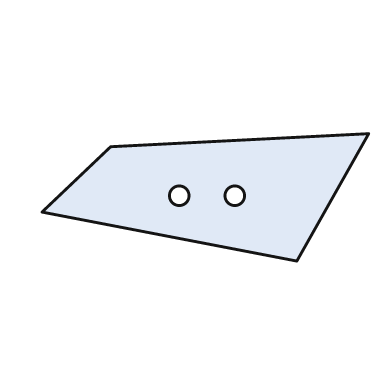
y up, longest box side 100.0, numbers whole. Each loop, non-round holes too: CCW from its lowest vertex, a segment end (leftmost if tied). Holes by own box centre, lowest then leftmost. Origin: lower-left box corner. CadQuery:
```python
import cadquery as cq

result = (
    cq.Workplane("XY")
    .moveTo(78.0, 0.0)
    .lineTo(100.0, 39.0)
    .lineTo(21.0, 35.0)
    .lineTo(0.0, 15.0)
    .close()
    .moveTo(42.0, 20.0)
    .circle(3.0)
    .moveTo(59.0, 20.0)
    .circle(3.0)
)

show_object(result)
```